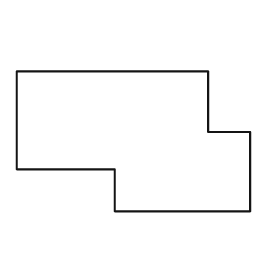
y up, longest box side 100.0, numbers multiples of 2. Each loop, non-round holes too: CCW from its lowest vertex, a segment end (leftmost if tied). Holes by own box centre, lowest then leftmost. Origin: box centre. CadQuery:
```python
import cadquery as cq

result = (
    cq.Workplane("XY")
    .moveTo(-8.0, -30.0)
    .lineTo(50.0, -30.0)
    .lineTo(50.0, 4.0)
    .lineTo(32.0, 4.0)
    .lineTo(32.0, 30.0)
    .lineTo(-50.0, 30.0)
    .lineTo(-50.0, -12.0)
    .lineTo(-8.0, -12.0)
    .close()
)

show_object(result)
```